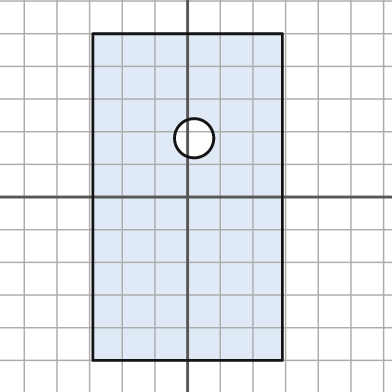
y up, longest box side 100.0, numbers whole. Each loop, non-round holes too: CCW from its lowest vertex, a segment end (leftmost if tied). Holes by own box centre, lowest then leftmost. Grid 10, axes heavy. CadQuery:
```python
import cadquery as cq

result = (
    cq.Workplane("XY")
    .moveTo(-29.0, -50.0)
    .lineTo(29.0, -50.0)
    .lineTo(29.0, 50.0)
    .lineTo(-29.0, 50.0)
    .close()
    .moveTo(2.0, 18.0)
    .circle(6.0)
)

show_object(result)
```